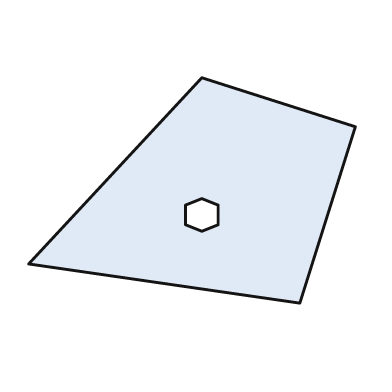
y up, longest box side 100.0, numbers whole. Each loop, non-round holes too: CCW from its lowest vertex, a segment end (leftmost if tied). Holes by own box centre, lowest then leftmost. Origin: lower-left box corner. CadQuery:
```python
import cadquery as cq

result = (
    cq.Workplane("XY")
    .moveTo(83.0, 0.0)
    .lineTo(100.0, 54.0)
    .lineTo(53.0, 69.0)
    .lineTo(0.0, 12.0)
    .close()
    .moveTo(53.0, 22.0)
    .lineTo(58.0, 24.0)
    .lineTo(58.0, 30.0)
    .lineTo(53.0, 32.0)
    .lineTo(48.0, 30.0)
    .lineTo(48.0, 24.0)
    .close()
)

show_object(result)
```